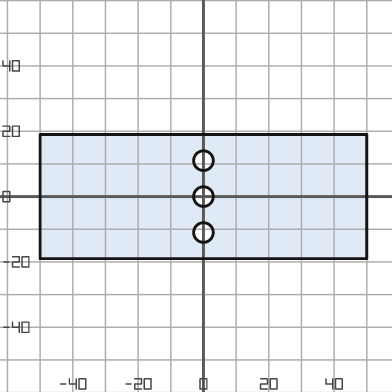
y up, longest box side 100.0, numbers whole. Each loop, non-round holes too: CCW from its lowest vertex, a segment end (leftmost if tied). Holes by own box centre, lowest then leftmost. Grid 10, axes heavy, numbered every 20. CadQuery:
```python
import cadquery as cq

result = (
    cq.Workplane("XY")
    .moveTo(-50.0, -19.0)
    .lineTo(50.0, -19.0)
    .lineTo(50.0, 19.0)
    .lineTo(-50.0, 19.0)
    .close()
    .moveTo(0.0, -11.0)
    .circle(3.0)
    .moveTo(0.0, 0.0)
    .circle(3.0)
    .moveTo(0.0, 11.0)
    .circle(3.0)
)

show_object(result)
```